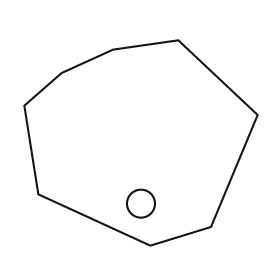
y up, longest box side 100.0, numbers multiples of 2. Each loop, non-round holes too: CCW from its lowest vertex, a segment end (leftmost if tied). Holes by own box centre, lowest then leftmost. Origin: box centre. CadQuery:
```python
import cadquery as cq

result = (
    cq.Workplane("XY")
    .moveTo(4.0, -44.0)
    .lineTo(30.0, -36.0)
    .lineTo(50.0, 12.0)
    .lineTo(16.0, 44.0)
    .lineTo(-12.0, 40.0)
    .lineTo(-34.0, 30.0)
    .lineTo(-50.0, 16.0)
    .lineTo(-44.0, -22.0)
    .close()
    .moveTo(0.0, -26.0)
    .circle(6.0)
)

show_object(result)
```